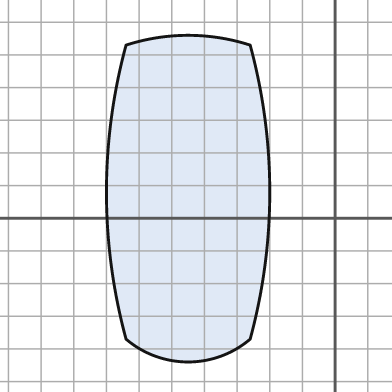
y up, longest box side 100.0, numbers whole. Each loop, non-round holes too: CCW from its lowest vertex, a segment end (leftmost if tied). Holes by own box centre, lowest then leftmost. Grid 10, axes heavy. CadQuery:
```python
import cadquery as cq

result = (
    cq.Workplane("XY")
    .moveTo(-64.0, -37.0)
    .threePointArc((-45.0, -44.0), (-26.0, -37.0))
    .threePointArc((-20.0, 8.0), (-26.0, 53.0))
    .threePointArc((-45.0, 56.0), (-64.0, 53.0))
    .threePointArc((-70.0, 8.0), (-64.0, -37.0))
    .close()
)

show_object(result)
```